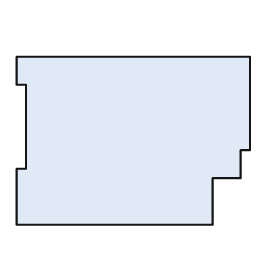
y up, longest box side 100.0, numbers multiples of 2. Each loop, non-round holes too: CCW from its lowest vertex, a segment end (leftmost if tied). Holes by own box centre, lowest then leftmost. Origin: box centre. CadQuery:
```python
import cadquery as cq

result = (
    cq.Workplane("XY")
    .moveTo(-50.0, -36.0)
    .lineTo(34.0, -36.0)
    .lineTo(34.0, -16.0)
    .lineTo(46.0, -16.0)
    .lineTo(46.0, -4.0)
    .lineTo(50.0, -4.0)
    .lineTo(50.0, 36.0)
    .lineTo(-50.0, 36.0)
    .lineTo(-50.0, 24.0)
    .lineTo(-46.0, 24.0)
    .lineTo(-46.0, -12.0)
    .lineTo(-50.0, -12.0)
    .close()
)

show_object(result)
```